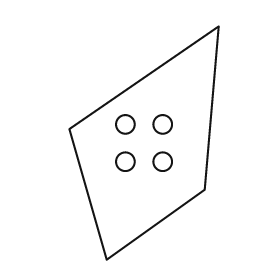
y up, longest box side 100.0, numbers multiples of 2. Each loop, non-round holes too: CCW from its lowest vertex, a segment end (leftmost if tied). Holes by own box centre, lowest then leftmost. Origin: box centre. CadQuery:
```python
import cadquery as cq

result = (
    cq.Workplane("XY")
    .moveTo(-16.0, -50.0)
    .lineTo(26.0, -20.0)
    .lineTo(32.0, 50.0)
    .lineTo(-32.0, 6.0)
    .close()
    .moveTo(-8.0, -8.0)
    .circle(4.0)
    .moveTo(8.0, -8.0)
    .circle(4.0)
    .moveTo(-8.0, 8.0)
    .circle(4.0)
    .moveTo(8.0, 8.0)
    .circle(4.0)
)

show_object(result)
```